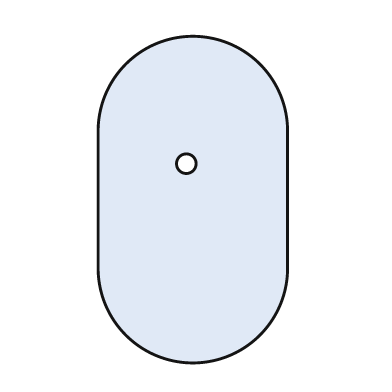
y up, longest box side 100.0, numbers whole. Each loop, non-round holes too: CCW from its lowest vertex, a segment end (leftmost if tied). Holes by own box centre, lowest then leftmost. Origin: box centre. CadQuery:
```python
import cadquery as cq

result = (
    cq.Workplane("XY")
    .moveTo(-29.0, -21.0)
    .threePointArc((0.0, -50.0), (29.0, -21.0))
    .lineTo(29.0, 21.0)
    .threePointArc((0.0, 50.0), (-29.0, 21.0))
    .close()
    .moveTo(-2.0, 11.0)
    .circle(3.0)
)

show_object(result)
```